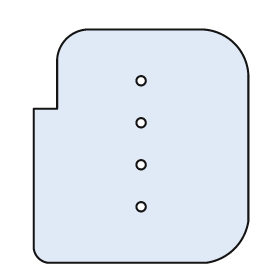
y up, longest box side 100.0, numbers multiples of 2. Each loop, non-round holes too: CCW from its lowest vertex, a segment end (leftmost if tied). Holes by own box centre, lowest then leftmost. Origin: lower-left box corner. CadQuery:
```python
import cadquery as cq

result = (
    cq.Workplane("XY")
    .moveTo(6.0, 0.0)
    .lineTo(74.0, 0.0)
    .threePointArc((86.0, 6.0), (92.0, 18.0))
    .lineTo(92.0, 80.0)
    .threePointArc((86.0, 94.0), (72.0, 100.0))
    .lineTo(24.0, 100.0)
    .threePointArc((14.0, 96.0), (10.0, 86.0))
    .lineTo(10.0, 66.0)
    .lineTo(0.0, 66.0)
    .lineTo(0.0, 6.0)
    .threePointArc((2.0, 2.0), (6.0, 0.0))
    .close()
    .moveTo(46.0, 24.0)
    .circle(2.0)
    .moveTo(46.0, 42.0)
    .circle(2.0)
    .moveTo(46.0, 60.0)
    .circle(2.0)
    .moveTo(46.0, 78.0)
    .circle(2.0)
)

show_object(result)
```